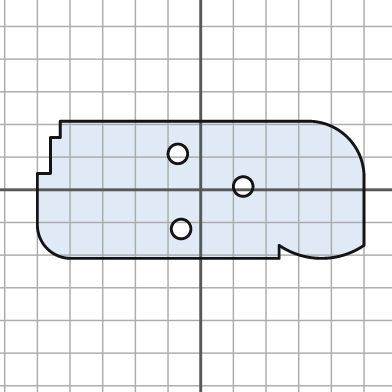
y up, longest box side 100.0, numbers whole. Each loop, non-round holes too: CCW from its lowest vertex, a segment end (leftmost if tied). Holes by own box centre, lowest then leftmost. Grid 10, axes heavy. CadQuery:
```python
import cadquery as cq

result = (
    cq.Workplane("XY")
    .moveTo(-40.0, -21.0)
    .lineTo(24.0, -21.0)
    .lineTo(24.0, -17.0)
    .threePointArc((37.0, -21.0), (50.0, -17.0))
    .lineTo(50.0, 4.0)
    .threePointArc((45.0, 16.0), (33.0, 21.0))
    .lineTo(-43.0, 21.0)
    .lineTo(-43.0, 16.0)
    .lineTo(-46.0, 16.0)
    .lineTo(-46.0, 5.0)
    .lineTo(-50.0, 5.0)
    .lineTo(-50.0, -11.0)
    .threePointArc((-47.0, -18.0), (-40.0, -21.0))
    .close()
    .moveTo(-6.0, -12.0)
    .circle(3.0)
    .moveTo(13.0, 1.0)
    .circle(3.0)
    .moveTo(-7.0, 11.0)
    .circle(3.0)
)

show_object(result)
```